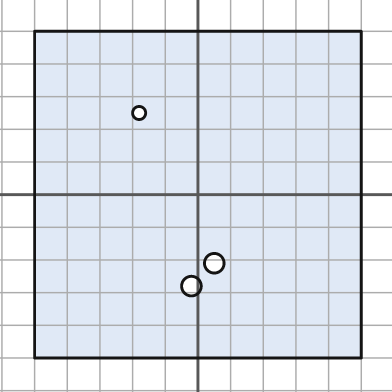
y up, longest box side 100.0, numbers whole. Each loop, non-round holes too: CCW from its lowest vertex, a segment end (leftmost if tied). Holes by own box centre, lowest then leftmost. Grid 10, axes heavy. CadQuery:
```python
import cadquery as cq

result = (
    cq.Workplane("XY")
    .moveTo(-50.0, -50.0)
    .lineTo(50.0, -50.0)
    .lineTo(50.0, 50.0)
    .lineTo(-50.0, 50.0)
    .close()
    .moveTo(-2.0, -28.0)
    .circle(3.0)
    .moveTo(5.0, -21.0)
    .circle(3.0)
    .moveTo(-18.0, 25.0)
    .circle(2.0)
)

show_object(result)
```